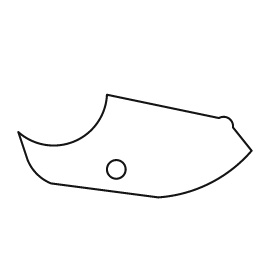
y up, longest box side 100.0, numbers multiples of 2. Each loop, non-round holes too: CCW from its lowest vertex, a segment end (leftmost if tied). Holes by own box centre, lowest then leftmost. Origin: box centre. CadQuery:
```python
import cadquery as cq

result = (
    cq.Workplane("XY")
    .moveTo(10.0, -22.0)
    .threePointArc((32.0, -16.0), (50.0, -2.0))
    .lineTo(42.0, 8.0)
    .threePointArc((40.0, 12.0), (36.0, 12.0))
    .lineTo(-12.0, 22.0)
    .threePointArc((-26.0, 2.0), (-50.0, 6.0))
    .lineTo(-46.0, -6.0)
    .threePointArc((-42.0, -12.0), (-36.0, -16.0))
    .close()
    .moveTo(-8.0, -10.0)
    .circle(4.0)
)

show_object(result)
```